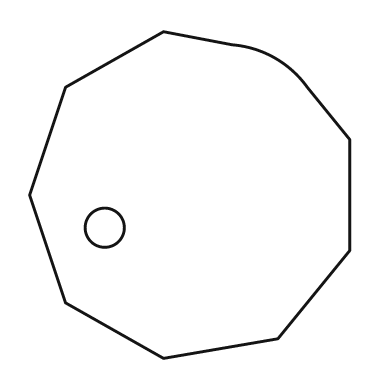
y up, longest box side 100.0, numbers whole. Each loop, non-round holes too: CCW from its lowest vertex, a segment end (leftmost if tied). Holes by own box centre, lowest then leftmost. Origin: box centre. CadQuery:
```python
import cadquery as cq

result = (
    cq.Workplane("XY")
    .moveTo(-8.0, -50.0)
    .lineTo(27.0, -44.0)
    .lineTo(49.0, -17.0)
    .lineTo(49.0, 17.0)
    .lineTo(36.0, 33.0)
    .threePointArc((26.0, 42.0), (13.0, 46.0))
    .lineTo(-8.0, 50.0)
    .lineTo(-38.0, 33.0)
    .lineTo(-49.0, 0.0)
    .lineTo(-38.0, -33.0)
    .close()
    .moveTo(-26.0, -10.0)
    .circle(6.0)
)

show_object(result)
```